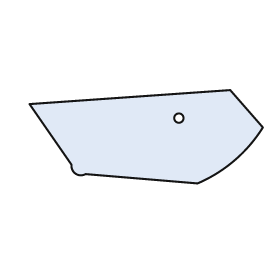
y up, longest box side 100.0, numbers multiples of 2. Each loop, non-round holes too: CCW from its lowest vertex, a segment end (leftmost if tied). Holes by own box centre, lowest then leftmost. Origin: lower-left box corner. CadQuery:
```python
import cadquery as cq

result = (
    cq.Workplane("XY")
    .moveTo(72.0, 0.0)
    .threePointArc((88.0, 10.0), (100.0, 24.0))
    .lineTo(86.0, 40.0)
    .lineTo(0.0, 34.0)
    .lineTo(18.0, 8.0)
    .threePointArc((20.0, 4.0), (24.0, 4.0))
    .close()
    .moveTo(64.0, 28.0)
    .circle(2.0)
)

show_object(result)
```